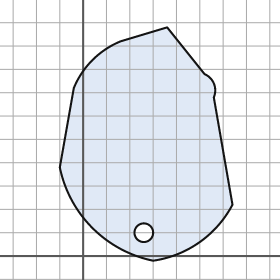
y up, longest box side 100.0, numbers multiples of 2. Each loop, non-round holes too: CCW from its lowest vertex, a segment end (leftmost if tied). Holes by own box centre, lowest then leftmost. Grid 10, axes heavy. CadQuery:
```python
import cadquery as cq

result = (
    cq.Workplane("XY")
    .moveTo(30.0, -2.0)
    .threePointArc((50.0, 6.0), (64.0, 22.0))
    .lineTo(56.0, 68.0)
    .threePointArc((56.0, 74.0), (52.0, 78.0))
    .lineTo(36.0, 98.0)
    .lineTo(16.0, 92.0)
    .threePointArc((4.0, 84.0), (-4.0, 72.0))
    .lineTo(-10.0, 38.0)
    .threePointArc((4.0, 12.0), (30.0, -2.0))
    .close()
    .moveTo(26.0, 10.0)
    .circle(4.0)
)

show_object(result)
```